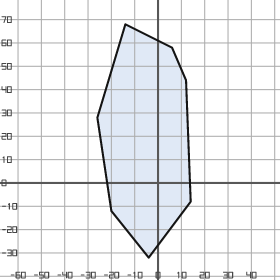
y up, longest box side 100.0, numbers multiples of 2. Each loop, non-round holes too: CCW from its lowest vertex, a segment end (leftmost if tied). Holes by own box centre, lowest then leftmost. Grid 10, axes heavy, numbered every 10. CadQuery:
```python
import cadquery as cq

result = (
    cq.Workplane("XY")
    .moveTo(-4.0, -32.0)
    .lineTo(14.0, -8.0)
    .lineTo(12.0, 44.0)
    .lineTo(6.0, 58.0)
    .lineTo(-14.0, 68.0)
    .lineTo(-26.0, 28.0)
    .lineTo(-20.0, -12.0)
    .close()
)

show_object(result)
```